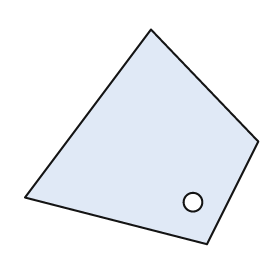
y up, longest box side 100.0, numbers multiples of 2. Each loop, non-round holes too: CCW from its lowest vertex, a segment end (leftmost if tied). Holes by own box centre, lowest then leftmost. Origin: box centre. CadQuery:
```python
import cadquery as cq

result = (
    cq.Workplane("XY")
    .moveTo(28.0, -46.0)
    .lineTo(50.0, -2.0)
    .lineTo(4.0, 46.0)
    .lineTo(-50.0, -26.0)
    .close()
    .moveTo(22.0, -28.0)
    .circle(4.0)
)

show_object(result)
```